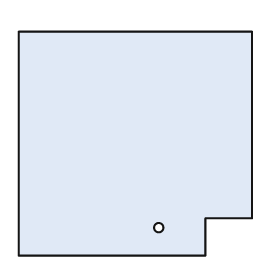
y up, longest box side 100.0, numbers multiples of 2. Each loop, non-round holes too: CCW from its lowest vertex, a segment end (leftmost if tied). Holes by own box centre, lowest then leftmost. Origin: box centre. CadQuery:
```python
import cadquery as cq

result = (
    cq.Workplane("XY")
    .moveTo(-50.0, -48.0)
    .lineTo(30.0, -48.0)
    .lineTo(30.0, -32.0)
    .lineTo(50.0, -32.0)
    .lineTo(50.0, 48.0)
    .lineTo(-50.0, 48.0)
    .close()
    .moveTo(10.0, -36.0)
    .circle(2.0)
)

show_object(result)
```